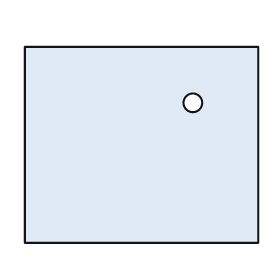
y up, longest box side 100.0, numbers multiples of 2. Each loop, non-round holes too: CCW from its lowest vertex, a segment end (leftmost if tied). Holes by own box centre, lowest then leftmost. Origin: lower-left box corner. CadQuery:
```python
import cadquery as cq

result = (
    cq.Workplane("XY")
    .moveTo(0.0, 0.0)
    .lineTo(100.0, 0.0)
    .lineTo(100.0, 84.0)
    .lineTo(0.0, 84.0)
    .close()
    .moveTo(72.0, 60.0)
    .circle(4.0)
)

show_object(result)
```